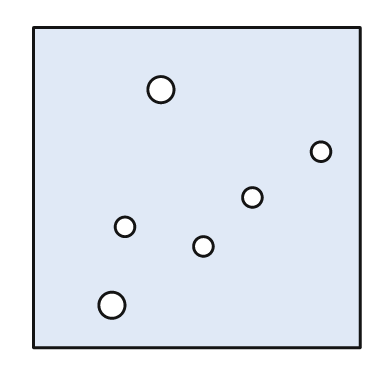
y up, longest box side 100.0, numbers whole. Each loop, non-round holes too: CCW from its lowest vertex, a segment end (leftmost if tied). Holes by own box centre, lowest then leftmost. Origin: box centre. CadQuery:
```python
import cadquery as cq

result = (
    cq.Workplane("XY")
    .moveTo(-50.0, -49.0)
    .lineTo(50.0, -49.0)
    .lineTo(50.0, 49.0)
    .lineTo(-50.0, 49.0)
    .close()
    .moveTo(-26.0, -36.0)
    .circle(4.0)
    .moveTo(2.0, -18.0)
    .circle(3.0)
    .moveTo(-22.0, -12.0)
    .circle(3.0)
    .moveTo(17.0, -3.0)
    .circle(3.0)
    .moveTo(38.0, 11.0)
    .circle(3.0)
    .moveTo(-11.0, 30.0)
    .circle(4.0)
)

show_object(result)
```